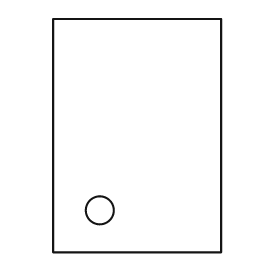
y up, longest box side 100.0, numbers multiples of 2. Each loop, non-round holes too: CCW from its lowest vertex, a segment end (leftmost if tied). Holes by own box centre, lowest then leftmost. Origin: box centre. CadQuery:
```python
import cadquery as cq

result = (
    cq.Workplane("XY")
    .moveTo(-36.0, -50.0)
    .lineTo(36.0, -50.0)
    .lineTo(36.0, 50.0)
    .lineTo(-36.0, 50.0)
    .close()
    .moveTo(-16.0, -32.0)
    .circle(6.0)
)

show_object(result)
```